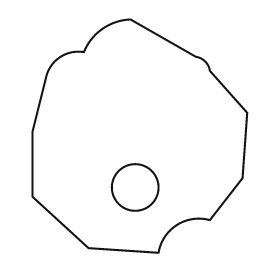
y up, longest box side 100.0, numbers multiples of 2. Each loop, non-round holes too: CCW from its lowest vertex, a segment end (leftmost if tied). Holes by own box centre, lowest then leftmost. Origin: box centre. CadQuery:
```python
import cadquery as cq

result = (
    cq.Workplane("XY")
    .moveTo(8.0, -50.0)
    .threePointArc((16.0, -38.0), (30.0, -36.0))
    .lineTo(44.0, -18.0)
    .lineTo(46.0, 10.0)
    .lineTo(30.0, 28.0)
    .threePointArc((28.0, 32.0), (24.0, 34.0))
    .lineTo(-4.0, 50.0)
    .threePointArc((-16.0, 46.0), (-24.0, 36.0))
    .threePointArc((-34.0, 34.0), (-40.0, 26.0))
    .lineTo(-46.0, 2.0)
    .lineTo(-46.0, -26.0)
    .lineTo(-22.0, -48.0)
    .close()
    .moveTo(-2.0, -22.0)
    .circle(10.0)
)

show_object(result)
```